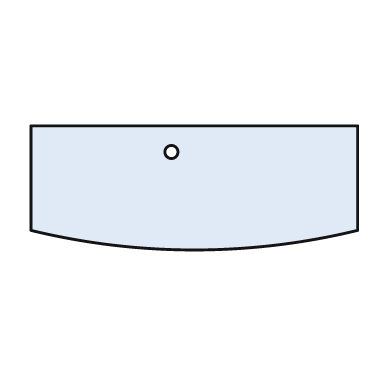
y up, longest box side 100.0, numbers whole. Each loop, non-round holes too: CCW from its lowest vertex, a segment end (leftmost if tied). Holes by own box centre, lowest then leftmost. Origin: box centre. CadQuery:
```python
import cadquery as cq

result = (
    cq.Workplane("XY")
    .moveTo(-50.0, -13.0)
    .threePointArc((0.0, -19.0), (50.0, -13.0))
    .lineTo(50.0, 19.0)
    .lineTo(-50.0, 19.0)
    .close()
    .moveTo(-7.0, 11.0)
    .circle(2.0)
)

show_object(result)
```